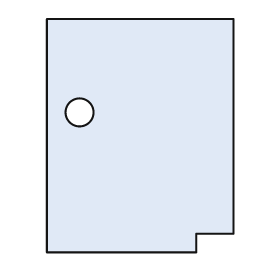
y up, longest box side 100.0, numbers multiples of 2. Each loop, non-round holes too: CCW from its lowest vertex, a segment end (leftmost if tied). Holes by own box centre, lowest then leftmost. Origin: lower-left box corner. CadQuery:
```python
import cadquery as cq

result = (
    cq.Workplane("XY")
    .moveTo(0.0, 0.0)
    .lineTo(64.0, 0.0)
    .lineTo(64.0, 8.0)
    .lineTo(80.0, 8.0)
    .lineTo(80.0, 100.0)
    .lineTo(0.0, 100.0)
    .close()
    .moveTo(14.0, 60.0)
    .circle(6.0)
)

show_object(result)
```